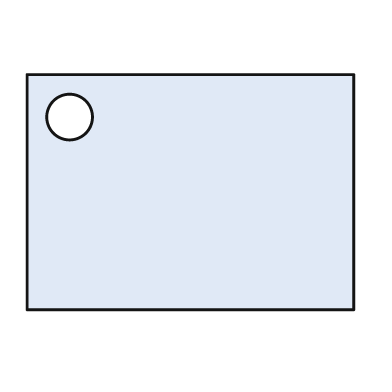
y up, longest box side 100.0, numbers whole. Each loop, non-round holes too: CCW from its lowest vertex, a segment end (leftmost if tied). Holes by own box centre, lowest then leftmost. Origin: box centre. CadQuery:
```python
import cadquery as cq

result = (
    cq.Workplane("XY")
    .moveTo(-50.0, -36.0)
    .lineTo(50.0, -36.0)
    .lineTo(50.0, 36.0)
    .lineTo(-50.0, 36.0)
    .close()
    .moveTo(-37.0, 23.0)
    .circle(7.0)
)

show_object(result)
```